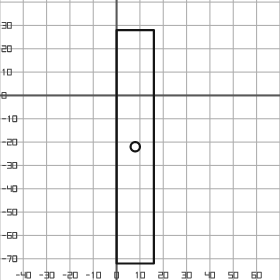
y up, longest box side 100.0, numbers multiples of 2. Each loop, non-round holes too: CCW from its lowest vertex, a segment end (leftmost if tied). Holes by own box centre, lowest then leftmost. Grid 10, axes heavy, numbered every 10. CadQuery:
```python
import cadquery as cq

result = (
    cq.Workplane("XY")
    .moveTo(0.0, -72.0)
    .lineTo(16.0, -72.0)
    .lineTo(16.0, 28.0)
    .lineTo(0.0, 28.0)
    .close()
    .moveTo(8.0, -22.0)
    .circle(2.0)
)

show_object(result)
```